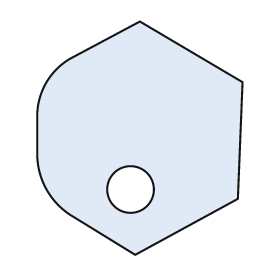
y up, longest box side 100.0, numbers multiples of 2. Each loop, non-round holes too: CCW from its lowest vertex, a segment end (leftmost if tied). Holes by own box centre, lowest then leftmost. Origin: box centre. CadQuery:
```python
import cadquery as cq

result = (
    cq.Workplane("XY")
    .moveTo(-2.0, -50.0)
    .lineTo(42.0, -26.0)
    .lineTo(44.0, 24.0)
    .lineTo(0.0, 50.0)
    .lineTo(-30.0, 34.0)
    .threePointArc((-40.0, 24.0), (-44.0, 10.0))
    .lineTo(-44.0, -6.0)
    .threePointArc((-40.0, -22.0), (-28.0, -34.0))
    .close()
    .moveTo(-4.0, -22.0)
    .circle(10.0)
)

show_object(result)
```